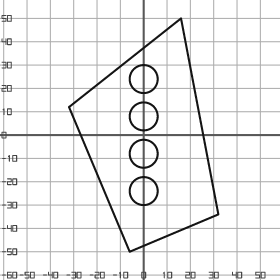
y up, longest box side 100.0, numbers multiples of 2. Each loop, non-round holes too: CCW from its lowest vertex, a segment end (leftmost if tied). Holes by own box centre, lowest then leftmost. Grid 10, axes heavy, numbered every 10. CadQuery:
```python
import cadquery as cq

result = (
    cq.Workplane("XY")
    .moveTo(-6.0, -50.0)
    .lineTo(32.0, -34.0)
    .lineTo(16.0, 50.0)
    .lineTo(-32.0, 12.0)
    .close()
    .moveTo(0.0, -24.0)
    .circle(6.0)
    .moveTo(0.0, -8.0)
    .circle(6.0)
    .moveTo(0.0, 8.0)
    .circle(6.0)
    .moveTo(0.0, 24.0)
    .circle(6.0)
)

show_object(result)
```